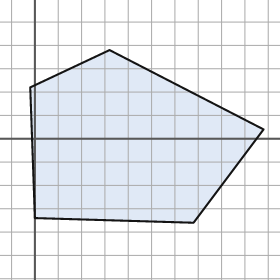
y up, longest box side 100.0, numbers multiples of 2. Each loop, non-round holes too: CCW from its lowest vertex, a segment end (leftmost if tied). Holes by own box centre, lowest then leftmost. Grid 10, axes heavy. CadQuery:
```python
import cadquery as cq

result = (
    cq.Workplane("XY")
    .moveTo(68.0, -36.0)
    .lineTo(98.0, 4.0)
    .lineTo(32.0, 38.0)
    .lineTo(-2.0, 22.0)
    .lineTo(0.0, -34.0)
    .close()
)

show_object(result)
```